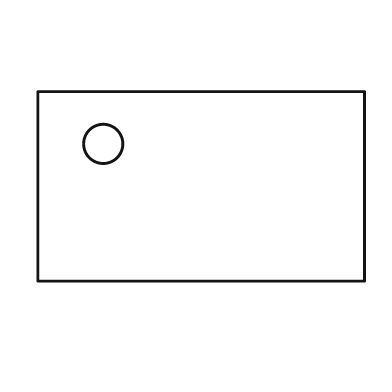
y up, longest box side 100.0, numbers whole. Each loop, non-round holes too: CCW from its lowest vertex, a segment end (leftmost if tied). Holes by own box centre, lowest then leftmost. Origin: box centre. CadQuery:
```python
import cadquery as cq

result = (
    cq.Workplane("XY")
    .moveTo(-50.0, -29.0)
    .lineTo(50.0, -29.0)
    .lineTo(50.0, 29.0)
    .lineTo(-50.0, 29.0)
    .close()
    .moveTo(-30.0, 13.0)
    .circle(6.0)
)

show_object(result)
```